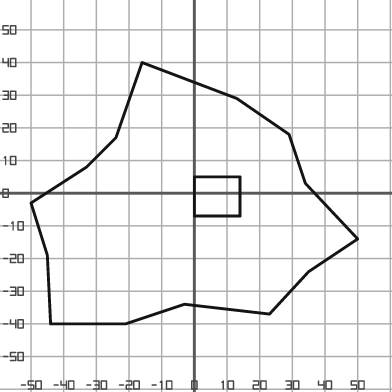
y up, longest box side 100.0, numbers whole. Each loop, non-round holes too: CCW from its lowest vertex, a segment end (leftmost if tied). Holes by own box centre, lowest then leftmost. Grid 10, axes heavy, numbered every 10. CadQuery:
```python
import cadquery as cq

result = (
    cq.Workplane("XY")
    .moveTo(-44.0, -40.0)
    .lineTo(-21.0, -40.0)
    .lineTo(-3.0, -34.0)
    .lineTo(23.0, -37.0)
    .lineTo(35.0, -24.0)
    .lineTo(50.0, -14.0)
    .lineTo(34.0, 3.0)
    .lineTo(29.0, 18.0)
    .lineTo(13.0, 29.0)
    .lineTo(-16.0, 40.0)
    .lineTo(-24.0, 17.0)
    .lineTo(-33.0, 8.0)
    .lineTo(-50.0, -3.0)
    .lineTo(-45.0, -19.0)
    .close()
    .moveTo(0.0, -7.0)
    .lineTo(14.0, -7.0)
    .lineTo(14.0, 5.0)
    .lineTo(0.0, 5.0)
    .close()
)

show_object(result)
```